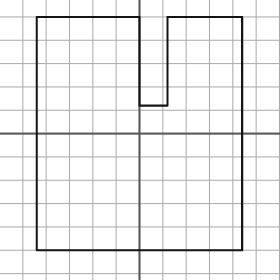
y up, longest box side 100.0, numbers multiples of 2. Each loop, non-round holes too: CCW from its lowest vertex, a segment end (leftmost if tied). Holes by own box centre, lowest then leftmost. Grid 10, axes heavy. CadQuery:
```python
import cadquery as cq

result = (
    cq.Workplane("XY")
    .moveTo(-44.0, -50.0)
    .lineTo(44.0, -50.0)
    .lineTo(44.0, 50.0)
    .lineTo(12.0, 50.0)
    .lineTo(12.0, 12.0)
    .lineTo(0.0, 12.0)
    .lineTo(0.0, 50.0)
    .lineTo(-44.0, 50.0)
    .close()
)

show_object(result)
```